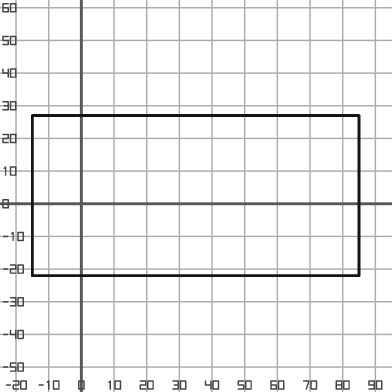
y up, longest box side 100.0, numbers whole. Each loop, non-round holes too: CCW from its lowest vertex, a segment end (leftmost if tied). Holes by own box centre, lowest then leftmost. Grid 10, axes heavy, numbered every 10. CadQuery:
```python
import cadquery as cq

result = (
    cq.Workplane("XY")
    .moveTo(-15.0, -22.0)
    .lineTo(85.0, -22.0)
    .lineTo(85.0, 27.0)
    .lineTo(-15.0, 27.0)
    .close()
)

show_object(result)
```